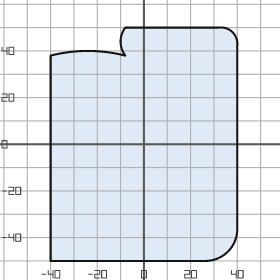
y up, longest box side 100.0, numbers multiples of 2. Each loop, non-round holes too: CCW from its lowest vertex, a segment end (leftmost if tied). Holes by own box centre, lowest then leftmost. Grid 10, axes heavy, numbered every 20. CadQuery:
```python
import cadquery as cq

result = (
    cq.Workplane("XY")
    .moveTo(-40.0, -50.0)
    .lineTo(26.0, -50.0)
    .threePointArc((36.0, -46.0), (40.0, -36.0))
    .lineTo(40.0, 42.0)
    .threePointArc((38.0, 48.0), (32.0, 50.0))
    .lineTo(-8.0, 50.0)
    .threePointArc((-10.0, 44.0), (-8.0, 38.0))
    .threePointArc((-24.0, 40.0), (-40.0, 38.0))
    .close()
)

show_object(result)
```